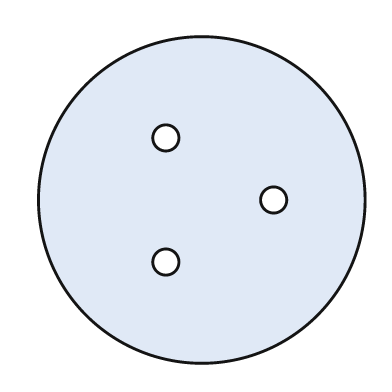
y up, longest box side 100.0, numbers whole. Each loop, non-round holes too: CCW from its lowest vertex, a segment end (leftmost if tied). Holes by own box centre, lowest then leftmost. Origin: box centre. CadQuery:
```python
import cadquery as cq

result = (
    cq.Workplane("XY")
    .moveTo(0.0, 0.0)
    .circle(50.0)
    .moveTo(-11.0, -19.0)
    .circle(4.0)
    .moveTo(22.0, 0.0)
    .circle(4.0)
    .moveTo(-11.0, 19.0)
    .circle(4.0)
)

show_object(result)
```